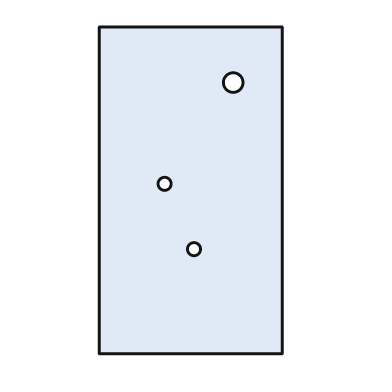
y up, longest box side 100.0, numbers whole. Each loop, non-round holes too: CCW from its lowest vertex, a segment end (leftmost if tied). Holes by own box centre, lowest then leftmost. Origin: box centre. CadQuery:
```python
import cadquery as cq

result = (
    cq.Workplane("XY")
    .moveTo(-28.0, -50.0)
    .lineTo(28.0, -50.0)
    .lineTo(28.0, 50.0)
    .lineTo(-28.0, 50.0)
    .close()
    .moveTo(1.0, -18.0)
    .circle(2.0)
    .moveTo(-8.0, 2.0)
    .circle(2.0)
    .moveTo(13.0, 33.0)
    .circle(3.0)
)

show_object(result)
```